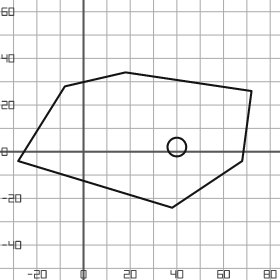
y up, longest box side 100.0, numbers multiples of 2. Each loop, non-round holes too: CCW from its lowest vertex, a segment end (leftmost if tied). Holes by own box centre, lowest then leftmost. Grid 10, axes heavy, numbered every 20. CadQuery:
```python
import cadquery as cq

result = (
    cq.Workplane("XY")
    .moveTo(38.0, -24.0)
    .lineTo(68.0, -4.0)
    .lineTo(72.0, 26.0)
    .lineTo(18.0, 34.0)
    .lineTo(-8.0, 28.0)
    .lineTo(-28.0, -4.0)
    .close()
    .moveTo(40.0, 2.0)
    .circle(4.0)
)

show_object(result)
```